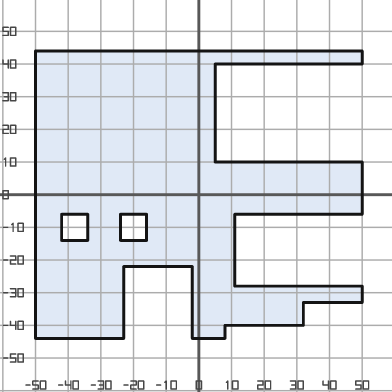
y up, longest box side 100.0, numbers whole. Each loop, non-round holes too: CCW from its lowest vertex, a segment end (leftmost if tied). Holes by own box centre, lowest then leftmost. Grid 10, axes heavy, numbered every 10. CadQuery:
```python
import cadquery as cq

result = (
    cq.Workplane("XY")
    .moveTo(-50.0, -44.0)
    .lineTo(-23.0, -44.0)
    .lineTo(-23.0, -22.0)
    .lineTo(-2.0, -22.0)
    .lineTo(-2.0, -44.0)
    .lineTo(8.0, -44.0)
    .lineTo(8.0, -40.0)
    .lineTo(32.0, -40.0)
    .lineTo(32.0, -33.0)
    .lineTo(50.0, -33.0)
    .lineTo(50.0, -28.0)
    .lineTo(11.0, -28.0)
    .lineTo(11.0, -6.0)
    .lineTo(50.0, -6.0)
    .lineTo(50.0, 10.0)
    .lineTo(5.0, 10.0)
    .lineTo(5.0, 40.0)
    .lineTo(50.0, 40.0)
    .lineTo(50.0, 44.0)
    .lineTo(-50.0, 44.0)
    .close()
    .moveTo(-42.0, -14.0)
    .lineTo(-34.0, -14.0)
    .lineTo(-34.0, -6.0)
    .lineTo(-42.0, -6.0)
    .close()
    .moveTo(-24.0, -14.0)
    .lineTo(-16.0, -14.0)
    .lineTo(-16.0, -6.0)
    .lineTo(-24.0, -6.0)
    .close()
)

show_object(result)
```